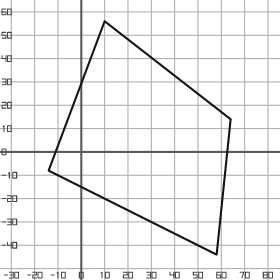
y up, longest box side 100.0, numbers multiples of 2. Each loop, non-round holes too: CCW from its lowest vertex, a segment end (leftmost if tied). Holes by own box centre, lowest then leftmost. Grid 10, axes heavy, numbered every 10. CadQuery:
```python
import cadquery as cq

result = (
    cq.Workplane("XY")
    .moveTo(58.0, -44.0)
    .lineTo(64.0, 14.0)
    .lineTo(10.0, 56.0)
    .lineTo(-14.0, -8.0)
    .close()
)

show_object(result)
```